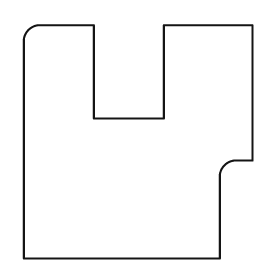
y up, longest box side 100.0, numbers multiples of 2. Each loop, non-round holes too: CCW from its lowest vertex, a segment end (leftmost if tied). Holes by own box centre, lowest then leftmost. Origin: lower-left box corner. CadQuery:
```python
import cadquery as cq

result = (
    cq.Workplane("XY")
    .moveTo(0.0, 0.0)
    .lineTo(84.0, 0.0)
    .lineTo(84.0, 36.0)
    .threePointArc((86.0, 40.0), (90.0, 42.0))
    .lineTo(98.0, 42.0)
    .lineTo(98.0, 100.0)
    .lineTo(60.0, 100.0)
    .lineTo(60.0, 60.0)
    .lineTo(30.0, 60.0)
    .lineTo(30.0, 100.0)
    .lineTo(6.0, 100.0)
    .threePointArc((2.0, 98.0), (0.0, 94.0))
    .close()
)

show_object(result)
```